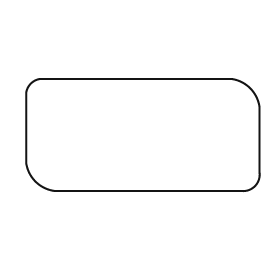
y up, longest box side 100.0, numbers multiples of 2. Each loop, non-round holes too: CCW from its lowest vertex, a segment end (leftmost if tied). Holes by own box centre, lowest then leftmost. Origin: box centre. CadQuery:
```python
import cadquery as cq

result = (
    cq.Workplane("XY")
    .moveTo(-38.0, -24.0)
    .lineTo(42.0, -24.0)
    .threePointArc((48.0, -22.0), (50.0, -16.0))
    .lineTo(50.0, 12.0)
    .threePointArc((46.0, 20.0), (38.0, 24.0))
    .lineTo(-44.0, 24.0)
    .threePointArc((-48.0, 22.0), (-50.0, 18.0))
    .lineTo(-50.0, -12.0)
    .threePointArc((-46.0, -20.0), (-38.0, -24.0))
    .close()
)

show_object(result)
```